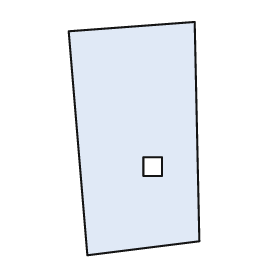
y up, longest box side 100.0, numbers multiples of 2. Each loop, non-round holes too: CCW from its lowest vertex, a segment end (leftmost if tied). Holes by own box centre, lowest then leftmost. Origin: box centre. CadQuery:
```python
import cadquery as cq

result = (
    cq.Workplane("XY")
    .moveTo(-20.0, -50.0)
    .lineTo(28.0, -44.0)
    .lineTo(26.0, 50.0)
    .lineTo(-28.0, 46.0)
    .close()
    .moveTo(4.0, -16.0)
    .lineTo(12.0, -16.0)
    .lineTo(12.0, -8.0)
    .lineTo(4.0, -8.0)
    .close()
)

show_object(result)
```